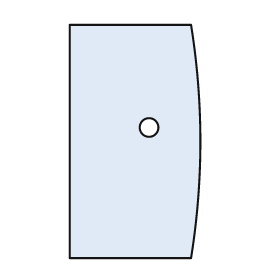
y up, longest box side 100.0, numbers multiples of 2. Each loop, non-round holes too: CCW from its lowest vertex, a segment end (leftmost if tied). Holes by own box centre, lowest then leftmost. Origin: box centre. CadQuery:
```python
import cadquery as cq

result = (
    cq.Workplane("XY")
    .moveTo(-28.0, -50.0)
    .lineTo(24.0, -50.0)
    .threePointArc((28.0, 0.0), (24.0, 50.0))
    .lineTo(-28.0, 50.0)
    .close()
    .moveTo(6.0, 6.0)
    .circle(4.0)
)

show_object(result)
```